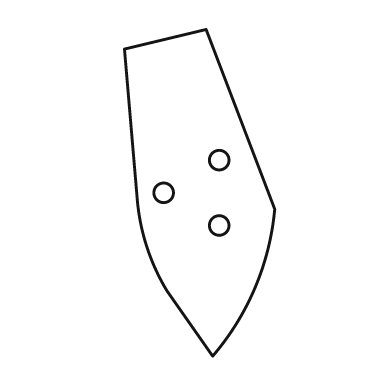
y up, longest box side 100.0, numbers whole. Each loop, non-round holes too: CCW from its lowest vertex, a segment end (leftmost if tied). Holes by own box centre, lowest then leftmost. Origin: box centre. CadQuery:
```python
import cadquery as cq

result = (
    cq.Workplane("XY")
    .moveTo(4.0, -50.0)
    .threePointArc((17.0, -29.0), (23.0, -5.0))
    .lineTo(2.0, 50.0)
    .lineTo(-23.0, 44.0)
    .lineTo(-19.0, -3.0)
    .threePointArc((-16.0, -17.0), (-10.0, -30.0))
    .close()
    .moveTo(6.0, -10.0)
    .circle(3.0)
    .moveTo(-11.0, 0.0)
    .circle(3.0)
    .moveTo(6.0, 10.0)
    .circle(3.0)
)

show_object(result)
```